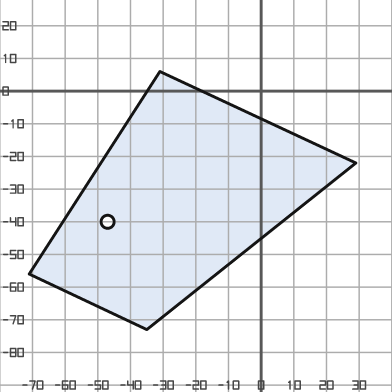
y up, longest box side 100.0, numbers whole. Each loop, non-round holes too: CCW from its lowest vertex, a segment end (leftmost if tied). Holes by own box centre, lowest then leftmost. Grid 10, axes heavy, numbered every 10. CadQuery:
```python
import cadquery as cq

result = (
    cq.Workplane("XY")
    .moveTo(-35.0, -73.0)
    .lineTo(29.0, -22.0)
    .lineTo(-31.0, 6.0)
    .lineTo(-71.0, -56.0)
    .close()
    .moveTo(-47.0, -40.0)
    .circle(2.0)
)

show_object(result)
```